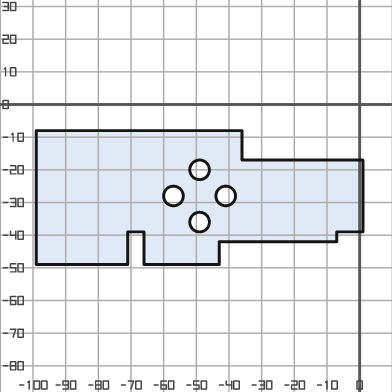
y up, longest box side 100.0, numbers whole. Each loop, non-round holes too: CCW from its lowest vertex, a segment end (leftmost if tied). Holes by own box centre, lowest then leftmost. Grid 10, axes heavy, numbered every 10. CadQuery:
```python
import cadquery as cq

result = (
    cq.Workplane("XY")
    .moveTo(-99.0, -49.0)
    .lineTo(-71.0, -49.0)
    .lineTo(-71.0, -39.0)
    .lineTo(-66.0, -39.0)
    .lineTo(-66.0, -49.0)
    .lineTo(-43.0, -49.0)
    .lineTo(-43.0, -42.0)
    .lineTo(-7.0, -42.0)
    .lineTo(-7.0, -39.0)
    .lineTo(1.0, -39.0)
    .lineTo(1.0, -17.0)
    .lineTo(-36.0, -17.0)
    .lineTo(-36.0, -8.0)
    .lineTo(-99.0, -8.0)
    .close()
    .moveTo(-49.0, -36.0)
    .circle(3.0)
    .moveTo(-57.0, -28.0)
    .circle(3.0)
    .moveTo(-41.0, -28.0)
    .circle(3.0)
    .moveTo(-49.0, -20.0)
    .circle(3.0)
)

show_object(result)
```